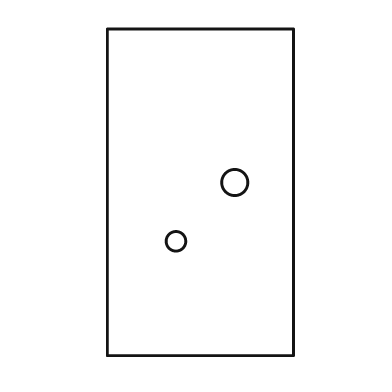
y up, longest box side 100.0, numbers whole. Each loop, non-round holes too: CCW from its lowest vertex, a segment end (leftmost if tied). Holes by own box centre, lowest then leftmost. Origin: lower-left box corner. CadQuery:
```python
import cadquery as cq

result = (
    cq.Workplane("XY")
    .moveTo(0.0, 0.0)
    .lineTo(57.0, 0.0)
    .lineTo(57.0, 100.0)
    .lineTo(0.0, 100.0)
    .close()
    .moveTo(21.0, 35.0)
    .circle(3.0)
    .moveTo(39.0, 53.0)
    .circle(4.0)
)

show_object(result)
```